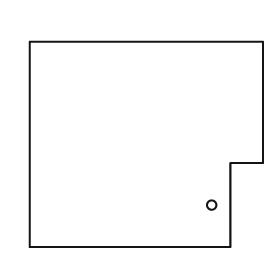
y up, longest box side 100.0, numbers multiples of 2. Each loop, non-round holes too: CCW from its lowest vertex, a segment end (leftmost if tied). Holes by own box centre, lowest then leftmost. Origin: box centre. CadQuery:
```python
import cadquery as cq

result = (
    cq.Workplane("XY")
    .moveTo(-50.0, -44.0)
    .lineTo(36.0, -44.0)
    .lineTo(36.0, -8.0)
    .lineTo(50.0, -8.0)
    .lineTo(50.0, 44.0)
    .lineTo(-50.0, 44.0)
    .close()
    .moveTo(28.0, -26.0)
    .circle(2.0)
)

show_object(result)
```